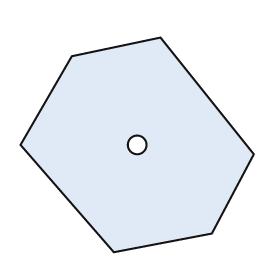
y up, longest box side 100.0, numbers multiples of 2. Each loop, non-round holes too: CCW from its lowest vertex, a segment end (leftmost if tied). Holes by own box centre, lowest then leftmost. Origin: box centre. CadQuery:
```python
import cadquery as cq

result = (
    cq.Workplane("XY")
    .moveTo(-10.0, -46.0)
    .lineTo(32.0, -38.0)
    .lineTo(50.0, -4.0)
    .lineTo(10.0, 46.0)
    .lineTo(-28.0, 38.0)
    .lineTo(-50.0, 0.0)
    .close()
    .moveTo(0.0, 0.0)
    .circle(4.0)
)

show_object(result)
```